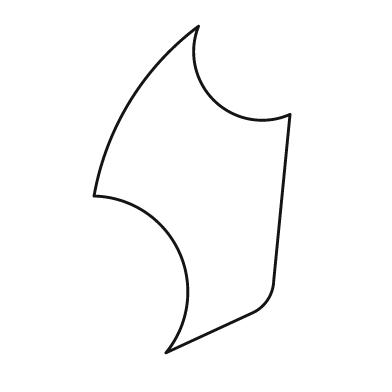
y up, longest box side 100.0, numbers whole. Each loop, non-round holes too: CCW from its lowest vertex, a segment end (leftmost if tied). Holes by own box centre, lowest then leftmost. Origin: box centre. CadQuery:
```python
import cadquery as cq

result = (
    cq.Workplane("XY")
    .moveTo(-8.0, -50.0)
    .lineTo(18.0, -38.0)
    .threePointArc((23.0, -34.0), (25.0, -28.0))
    .lineTo(30.0, 23.0)
    .threePointArc((7.0, 27.0), (2.0, 50.0))
    .threePointArc((-19.0, 27.0), (-30.0, -2.0))
    .threePointArc((-4.0, -19.0), (-8.0, -50.0))
    .close()
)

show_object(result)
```